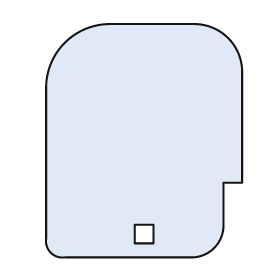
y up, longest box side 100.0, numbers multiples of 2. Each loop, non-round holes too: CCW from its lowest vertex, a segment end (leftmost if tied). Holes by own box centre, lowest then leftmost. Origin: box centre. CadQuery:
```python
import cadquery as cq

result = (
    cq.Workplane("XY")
    .moveTo(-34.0, -50.0)
    .lineTo(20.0, -50.0)
    .threePointArc((30.0, -46.0), (34.0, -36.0))
    .lineTo(34.0, -18.0)
    .lineTo(42.0, -18.0)
    .lineTo(42.0, 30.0)
    .threePointArc((36.0, 44.0), (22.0, 50.0))
    .lineTo(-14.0, 50.0)
    .threePointArc((-34.0, 42.0), (-42.0, 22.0))
    .lineTo(-42.0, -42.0)
    .threePointArc((-40.0, -48.0), (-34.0, -50.0))
    .close()
    .moveTo(-4.0, -44.0)
    .lineTo(4.0, -44.0)
    .lineTo(4.0, -36.0)
    .lineTo(-4.0, -36.0)
    .close()
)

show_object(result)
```